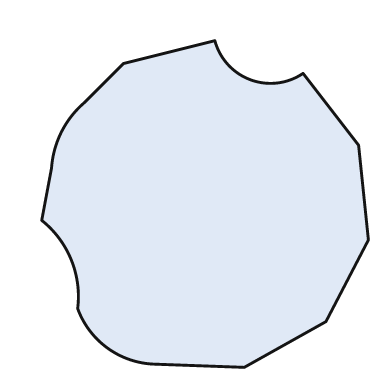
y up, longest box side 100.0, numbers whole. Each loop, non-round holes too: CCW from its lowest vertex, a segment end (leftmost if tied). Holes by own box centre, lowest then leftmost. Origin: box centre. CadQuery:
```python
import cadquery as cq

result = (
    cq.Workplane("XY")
    .moveTo(12.0, -50.0)
    .lineTo(37.0, -36.0)
    .lineTo(50.0, -11.0)
    .lineTo(47.0, 18.0)
    .lineTo(30.0, 40.0)
    .threePointArc((14.0, 38.0), (3.0, 50.0))
    .lineTo(-25.0, 43.0)
    .lineTo(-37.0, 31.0)
    .threePointArc((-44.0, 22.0), (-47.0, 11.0))
    .lineTo(-50.0, -5.0)
    .threePointArc((-41.0, -17.0), (-39.0, -32.0))
    .threePointArc((-30.0, -44.0), (-16.0, -49.0))
    .close()
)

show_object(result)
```